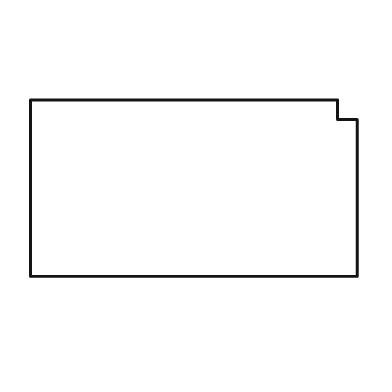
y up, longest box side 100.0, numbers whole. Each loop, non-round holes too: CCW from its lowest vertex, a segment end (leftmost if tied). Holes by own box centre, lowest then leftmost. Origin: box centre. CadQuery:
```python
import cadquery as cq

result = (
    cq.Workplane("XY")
    .moveTo(-50.0, -27.0)
    .lineTo(50.0, -27.0)
    .lineTo(50.0, 21.0)
    .lineTo(44.0, 21.0)
    .lineTo(44.0, 27.0)
    .lineTo(-50.0, 27.0)
    .close()
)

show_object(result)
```